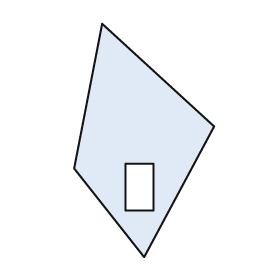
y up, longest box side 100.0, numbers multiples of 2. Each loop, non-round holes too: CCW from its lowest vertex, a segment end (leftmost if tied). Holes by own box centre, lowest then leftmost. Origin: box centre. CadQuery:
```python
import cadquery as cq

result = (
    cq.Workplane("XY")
    .moveTo(0.0, -50.0)
    .lineTo(30.0, 6.0)
    .lineTo(-18.0, 50.0)
    .lineTo(-30.0, -12.0)
    .close()
    .moveTo(-8.0, -30.0)
    .lineTo(4.0, -30.0)
    .lineTo(4.0, -10.0)
    .lineTo(-8.0, -10.0)
    .close()
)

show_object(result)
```